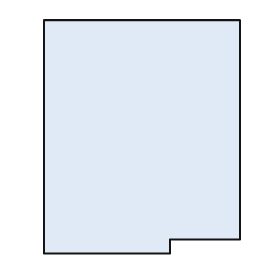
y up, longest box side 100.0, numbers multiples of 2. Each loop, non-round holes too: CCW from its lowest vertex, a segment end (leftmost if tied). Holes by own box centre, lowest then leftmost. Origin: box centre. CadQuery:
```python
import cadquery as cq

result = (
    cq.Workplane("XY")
    .moveTo(-42.0, -50.0)
    .lineTo(12.0, -50.0)
    .lineTo(12.0, -44.0)
    .lineTo(42.0, -44.0)
    .lineTo(42.0, 50.0)
    .lineTo(-42.0, 50.0)
    .close()
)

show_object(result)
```